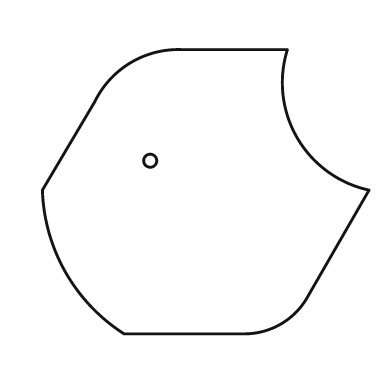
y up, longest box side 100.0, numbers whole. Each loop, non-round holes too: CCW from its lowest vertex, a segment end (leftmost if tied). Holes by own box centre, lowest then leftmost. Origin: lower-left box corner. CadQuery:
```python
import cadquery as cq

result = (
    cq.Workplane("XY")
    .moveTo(25.0, 0.0)
    .lineTo(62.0, 0.0)
    .threePointArc((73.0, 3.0), (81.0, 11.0))
    .lineTo(100.0, 44.0)
    .threePointArc((78.0, 60.0), (75.0, 87.0))
    .lineTo(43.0, 87.0)
    .threePointArc((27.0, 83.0), (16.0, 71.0))
    .lineTo(0.0, 44.0)
    .threePointArc((7.0, 19.0), (25.0, 0.0))
    .close()
    .moveTo(33.0, 53.0)
    .circle(2.0)
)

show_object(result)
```